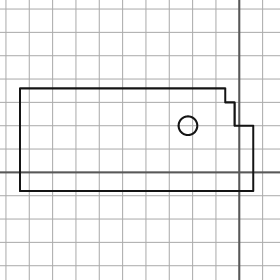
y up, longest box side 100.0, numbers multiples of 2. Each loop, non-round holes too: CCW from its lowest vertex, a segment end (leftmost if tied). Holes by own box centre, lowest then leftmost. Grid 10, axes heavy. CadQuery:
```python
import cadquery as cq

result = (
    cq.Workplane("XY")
    .moveTo(-94.0, -8.0)
    .lineTo(6.0, -8.0)
    .lineTo(6.0, 20.0)
    .lineTo(-2.0, 20.0)
    .lineTo(-2.0, 30.0)
    .lineTo(-6.0, 30.0)
    .lineTo(-6.0, 36.0)
    .lineTo(-94.0, 36.0)
    .close()
    .moveTo(-22.0, 20.0)
    .circle(4.0)
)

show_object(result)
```